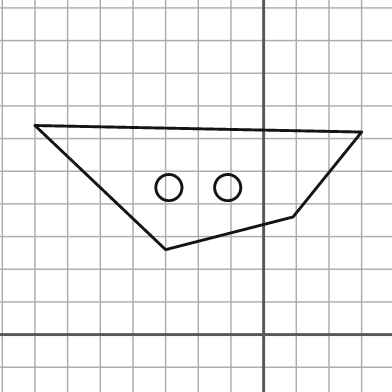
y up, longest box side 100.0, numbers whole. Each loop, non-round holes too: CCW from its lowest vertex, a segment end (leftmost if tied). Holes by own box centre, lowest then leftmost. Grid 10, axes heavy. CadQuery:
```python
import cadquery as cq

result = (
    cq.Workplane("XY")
    .moveTo(-30.0, 26.0)
    .lineTo(9.0, 36.0)
    .lineTo(30.0, 62.0)
    .lineTo(-70.0, 64.0)
    .close()
    .moveTo(-29.0, 45.0)
    .circle(4.0)
    .moveTo(-11.0, 45.0)
    .circle(4.0)
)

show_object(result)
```